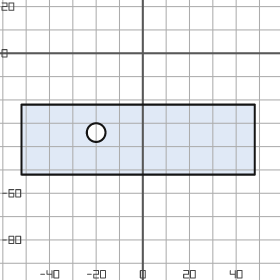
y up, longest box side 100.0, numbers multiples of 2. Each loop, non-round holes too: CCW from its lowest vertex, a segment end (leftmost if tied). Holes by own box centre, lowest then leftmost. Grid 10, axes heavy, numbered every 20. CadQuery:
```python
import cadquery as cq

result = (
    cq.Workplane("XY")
    .moveTo(-52.0, -52.0)
    .lineTo(48.0, -52.0)
    .lineTo(48.0, -22.0)
    .lineTo(-52.0, -22.0)
    .close()
    .moveTo(-20.0, -34.0)
    .circle(4.0)
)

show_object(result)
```